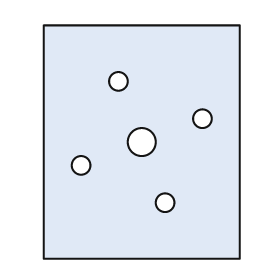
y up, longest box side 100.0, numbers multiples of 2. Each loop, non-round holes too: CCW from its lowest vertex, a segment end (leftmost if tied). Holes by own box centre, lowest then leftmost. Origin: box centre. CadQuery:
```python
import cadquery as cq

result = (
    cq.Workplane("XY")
    .moveTo(-42.0, -50.0)
    .lineTo(42.0, -50.0)
    .lineTo(42.0, 50.0)
    .lineTo(-42.0, 50.0)
    .close()
    .moveTo(10.0, -26.0)
    .circle(4.0)
    .moveTo(-26.0, -10.0)
    .circle(4.0)
    .moveTo(0.0, 0.0)
    .circle(6.0)
    .moveTo(26.0, 10.0)
    .circle(4.0)
    .moveTo(-10.0, 26.0)
    .circle(4.0)
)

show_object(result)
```